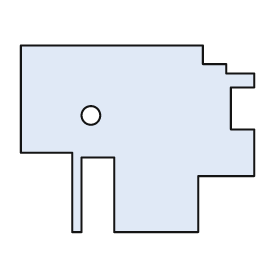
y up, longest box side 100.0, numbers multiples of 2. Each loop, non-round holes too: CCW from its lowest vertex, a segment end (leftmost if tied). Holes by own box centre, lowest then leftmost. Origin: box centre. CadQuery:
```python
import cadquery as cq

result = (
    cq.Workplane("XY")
    .moveTo(-28.0, -40.0)
    .lineTo(-24.0, -40.0)
    .lineTo(-24.0, -8.0)
    .lineTo(-10.0, -8.0)
    .lineTo(-10.0, -40.0)
    .lineTo(26.0, -40.0)
    .lineTo(26.0, -16.0)
    .lineTo(50.0, -16.0)
    .lineTo(50.0, 4.0)
    .lineTo(40.0, 4.0)
    .lineTo(40.0, 22.0)
    .lineTo(50.0, 22.0)
    .lineTo(50.0, 28.0)
    .lineTo(38.0, 28.0)
    .lineTo(38.0, 32.0)
    .lineTo(28.0, 32.0)
    .lineTo(28.0, 40.0)
    .lineTo(-50.0, 40.0)
    .lineTo(-50.0, -6.0)
    .lineTo(-28.0, -6.0)
    .close()
    .moveTo(-20.0, 10.0)
    .circle(4.0)
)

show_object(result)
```